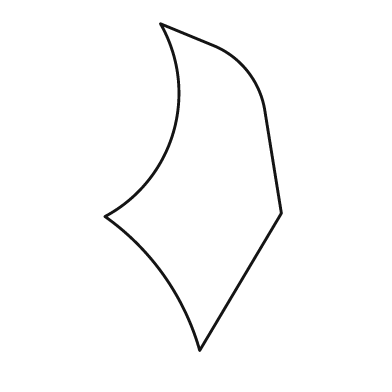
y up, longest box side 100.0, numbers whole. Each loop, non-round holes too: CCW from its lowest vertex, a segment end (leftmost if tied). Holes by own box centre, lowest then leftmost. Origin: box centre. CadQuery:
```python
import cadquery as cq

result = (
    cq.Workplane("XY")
    .moveTo(2.0, -50.0)
    .lineTo(27.0, -8.0)
    .lineTo(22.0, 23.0)
    .threePointArc((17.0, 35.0), (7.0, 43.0))
    .lineTo(-10.0, 50.0)
    .threePointArc((-6.0, 17.0), (-27.0, -9.0))
    .threePointArc((-9.0, -27.0), (2.0, -50.0))
    .close()
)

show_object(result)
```